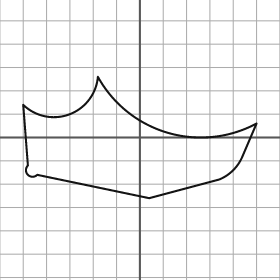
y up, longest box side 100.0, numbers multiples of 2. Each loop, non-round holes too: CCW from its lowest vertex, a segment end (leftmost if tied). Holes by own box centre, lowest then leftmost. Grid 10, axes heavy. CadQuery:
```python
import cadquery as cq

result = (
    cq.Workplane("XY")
    .moveTo(4.0, -26.0)
    .lineTo(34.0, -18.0)
    .threePointArc((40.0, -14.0), (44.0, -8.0))
    .lineTo(50.0, 6.0)
    .threePointArc((12.0, 2.0), (-18.0, 26.0))
    .threePointArc((-30.0, 10.0), (-50.0, 14.0))
    .lineTo(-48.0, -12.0)
    .threePointArc((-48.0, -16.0), (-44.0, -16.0))
    .close()
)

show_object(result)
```